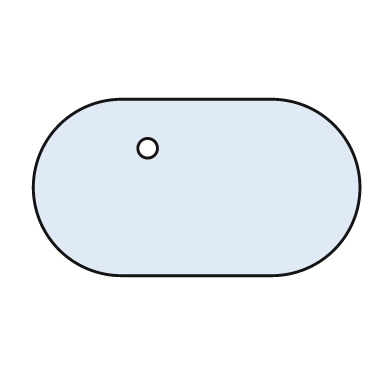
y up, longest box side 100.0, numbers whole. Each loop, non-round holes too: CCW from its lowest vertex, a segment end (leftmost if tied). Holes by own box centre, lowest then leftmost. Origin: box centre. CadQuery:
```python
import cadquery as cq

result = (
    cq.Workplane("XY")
    .moveTo(-23.0, -27.0)
    .lineTo(23.0, -27.0)
    .threePointArc((50.0, 0.0), (23.0, 27.0))
    .lineTo(-23.0, 27.0)
    .threePointArc((-50.0, 0.0), (-23.0, -27.0))
    .close()
    .moveTo(-15.0, 12.0)
    .circle(3.0)
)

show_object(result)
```